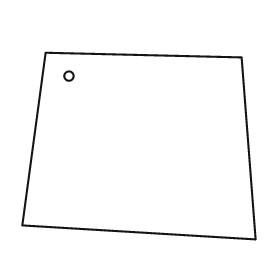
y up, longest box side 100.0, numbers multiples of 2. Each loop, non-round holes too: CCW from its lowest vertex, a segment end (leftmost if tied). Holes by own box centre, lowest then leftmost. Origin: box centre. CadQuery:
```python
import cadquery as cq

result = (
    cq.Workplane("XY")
    .moveTo(50.0, -40.0)
    .lineTo(44.0, 38.0)
    .lineTo(-40.0, 40.0)
    .lineTo(-50.0, -34.0)
    .close()
    .moveTo(-30.0, 30.0)
    .circle(2.0)
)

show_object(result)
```